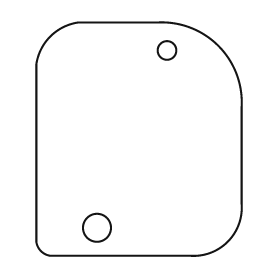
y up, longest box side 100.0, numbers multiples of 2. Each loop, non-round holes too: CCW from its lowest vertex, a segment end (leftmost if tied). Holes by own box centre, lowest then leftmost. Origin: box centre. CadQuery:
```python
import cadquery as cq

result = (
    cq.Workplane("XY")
    .moveTo(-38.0, -50.0)
    .lineTo(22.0, -50.0)
    .threePointArc((38.0, -44.0), (44.0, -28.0))
    .lineTo(44.0, 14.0)
    .threePointArc((34.0, 40.0), (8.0, 50.0))
    .lineTo(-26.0, 50.0)
    .threePointArc((-38.0, 44.0), (-44.0, 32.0))
    .lineTo(-44.0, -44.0)
    .threePointArc((-42.0, -48.0), (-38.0, -50.0))
    .close()
    .moveTo(-18.0, -38.0)
    .circle(6.0)
    .moveTo(12.0, 38.0)
    .circle(4.0)
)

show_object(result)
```